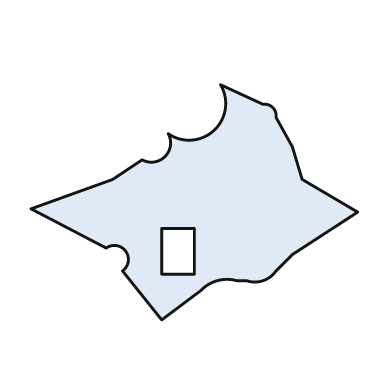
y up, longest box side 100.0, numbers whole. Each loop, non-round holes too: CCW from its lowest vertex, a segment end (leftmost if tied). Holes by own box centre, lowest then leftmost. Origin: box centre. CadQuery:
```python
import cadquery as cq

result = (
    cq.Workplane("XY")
    .moveTo(-10.0, -36.0)
    .lineTo(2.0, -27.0)
    .threePointArc((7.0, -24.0), (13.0, -24.0))
    .lineTo(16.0, -24.0)
    .threePointArc((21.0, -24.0), (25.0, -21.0))
    .lineTo(30.0, -16.0)
    .lineTo(50.0, -3.0)
    .lineTo(33.0, 7.0)
    .lineTo(30.0, 17.0)
    .lineTo(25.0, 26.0)
    .threePointArc((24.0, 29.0), (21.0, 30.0))
    .lineTo(8.0, 36.0)
    .threePointArc((6.0, 22.0), (-8.0, 21.0))
    .threePointArc((-9.0, 14.0), (-16.0, 13.0))
    .lineTo(-25.0, 7.0)
    .lineTo(-50.0, -2.0)
    .lineTo(-27.0, -14.0)
    .threePointArc((-21.0, -15.0), (-22.0, -21.0))
    .close()
    .moveTo(-10.0, -22.0)
    .lineTo(0.0, -22.0)
    .lineTo(0.0, -8.0)
    .lineTo(-10.0, -8.0)
    .close()
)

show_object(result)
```